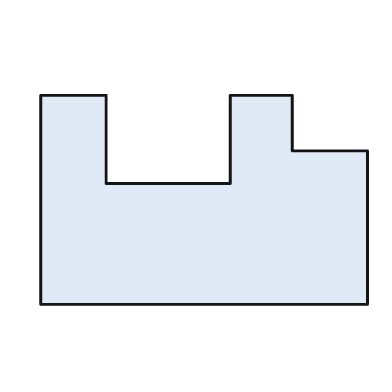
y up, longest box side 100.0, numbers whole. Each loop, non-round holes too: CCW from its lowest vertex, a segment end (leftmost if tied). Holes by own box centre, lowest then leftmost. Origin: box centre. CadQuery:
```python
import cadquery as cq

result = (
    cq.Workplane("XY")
    .moveTo(-50.0, -32.0)
    .lineTo(50.0, -32.0)
    .lineTo(50.0, 15.0)
    .lineTo(27.0, 15.0)
    .lineTo(27.0, 32.0)
    .lineTo(8.0, 32.0)
    .lineTo(8.0, 5.0)
    .lineTo(-30.0, 5.0)
    .lineTo(-30.0, 32.0)
    .lineTo(-50.0, 32.0)
    .close()
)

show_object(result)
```